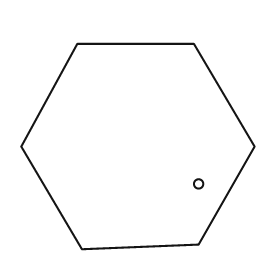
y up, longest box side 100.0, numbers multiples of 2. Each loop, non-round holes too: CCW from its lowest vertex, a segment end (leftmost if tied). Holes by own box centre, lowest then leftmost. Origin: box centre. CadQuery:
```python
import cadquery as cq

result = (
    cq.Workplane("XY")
    .moveTo(-24.0, -44.0)
    .lineTo(26.0, -42.0)
    .lineTo(50.0, 0.0)
    .lineTo(24.0, 44.0)
    .lineTo(-26.0, 44.0)
    .lineTo(-50.0, 0.0)
    .close()
    .moveTo(26.0, -16.0)
    .circle(2.0)
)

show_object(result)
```